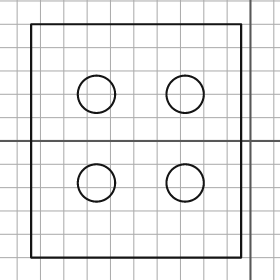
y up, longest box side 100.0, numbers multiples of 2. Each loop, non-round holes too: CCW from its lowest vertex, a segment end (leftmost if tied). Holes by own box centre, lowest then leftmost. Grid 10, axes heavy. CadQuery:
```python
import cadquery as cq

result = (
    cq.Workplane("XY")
    .moveTo(-94.0, -50.0)
    .lineTo(-4.0, -50.0)
    .lineTo(-4.0, 50.0)
    .lineTo(-94.0, 50.0)
    .close()
    .moveTo(-66.0, -18.0)
    .circle(8.0)
    .moveTo(-28.0, -18.0)
    .circle(8.0)
    .moveTo(-66.0, 20.0)
    .circle(8.0)
    .moveTo(-28.0, 20.0)
    .circle(8.0)
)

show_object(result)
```